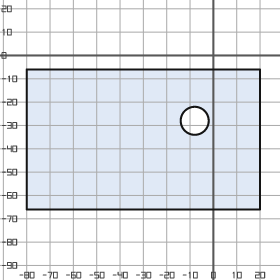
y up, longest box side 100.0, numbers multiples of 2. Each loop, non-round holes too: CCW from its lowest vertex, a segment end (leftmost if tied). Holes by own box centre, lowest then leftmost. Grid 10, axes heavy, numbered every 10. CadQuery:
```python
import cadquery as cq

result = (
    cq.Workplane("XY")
    .moveTo(-80.0, -66.0)
    .lineTo(20.0, -66.0)
    .lineTo(20.0, -6.0)
    .lineTo(-80.0, -6.0)
    .close()
    .moveTo(-8.0, -28.0)
    .circle(6.0)
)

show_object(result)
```